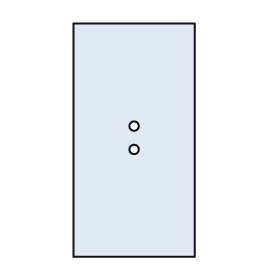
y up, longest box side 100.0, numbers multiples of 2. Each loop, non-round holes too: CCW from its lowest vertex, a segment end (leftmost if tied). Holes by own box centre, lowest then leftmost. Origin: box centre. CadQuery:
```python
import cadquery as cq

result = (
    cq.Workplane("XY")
    .moveTo(-26.0, -50.0)
    .lineTo(26.0, -50.0)
    .lineTo(26.0, 50.0)
    .lineTo(-26.0, 50.0)
    .close()
    .moveTo(0.0, -4.0)
    .circle(2.0)
    .moveTo(0.0, 6.0)
    .circle(2.0)
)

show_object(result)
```